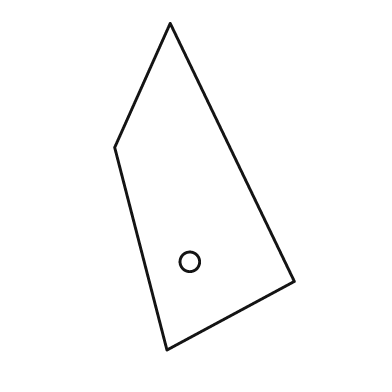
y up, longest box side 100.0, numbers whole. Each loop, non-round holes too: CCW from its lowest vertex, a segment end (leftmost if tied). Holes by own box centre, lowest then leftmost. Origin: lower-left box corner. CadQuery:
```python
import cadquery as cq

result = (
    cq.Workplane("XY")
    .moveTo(16.0, 0.0)
    .lineTo(55.0, 21.0)
    .lineTo(17.0, 100.0)
    .lineTo(0.0, 62.0)
    .close()
    .moveTo(23.0, 27.0)
    .circle(3.0)
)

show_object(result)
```